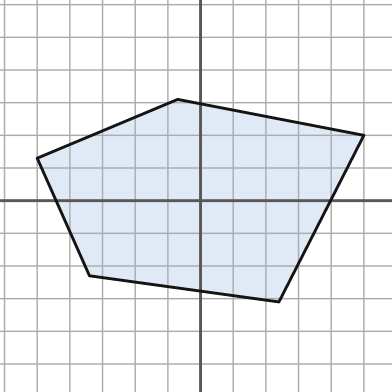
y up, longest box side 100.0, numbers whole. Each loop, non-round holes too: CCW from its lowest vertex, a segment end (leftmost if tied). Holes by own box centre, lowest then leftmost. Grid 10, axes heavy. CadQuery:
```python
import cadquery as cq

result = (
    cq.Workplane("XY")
    .moveTo(24.0, -31.0)
    .lineTo(50.0, 20.0)
    .lineTo(-7.0, 31.0)
    .lineTo(-50.0, 13.0)
    .lineTo(-34.0, -23.0)
    .close()
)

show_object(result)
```